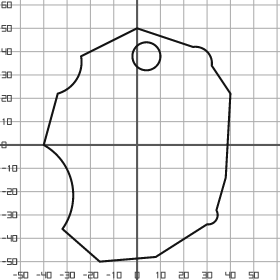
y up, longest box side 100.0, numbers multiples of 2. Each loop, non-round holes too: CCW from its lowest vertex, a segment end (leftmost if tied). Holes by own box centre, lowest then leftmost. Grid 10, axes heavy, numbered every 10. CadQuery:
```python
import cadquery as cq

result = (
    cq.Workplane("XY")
    .moveTo(-16.0, -50.0)
    .lineTo(8.0, -48.0)
    .lineTo(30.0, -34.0)
    .threePointArc((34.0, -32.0), (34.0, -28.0))
    .lineTo(38.0, -14.0)
    .lineTo(40.0, 22.0)
    .lineTo(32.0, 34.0)
    .threePointArc((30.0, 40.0), (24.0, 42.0))
    .lineTo(0.0, 50.0)
    .lineTo(-24.0, 38.0)
    .threePointArc((-26.0, 28.0), (-34.0, 22.0))
    .lineTo(-40.0, 0.0)
    .threePointArc((-28.0, -16.0), (-32.0, -36.0))
    .close()
    .moveTo(4.0, 38.0)
    .circle(6.0)
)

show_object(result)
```